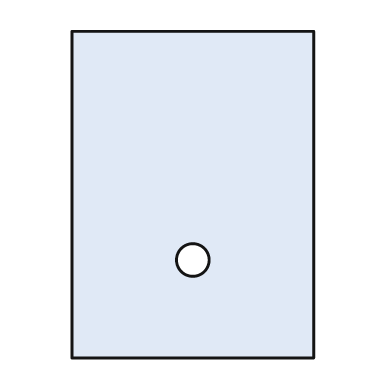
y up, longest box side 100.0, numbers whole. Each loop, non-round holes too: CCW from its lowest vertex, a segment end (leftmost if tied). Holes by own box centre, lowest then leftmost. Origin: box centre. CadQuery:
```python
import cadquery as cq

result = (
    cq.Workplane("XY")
    .moveTo(-37.0, -50.0)
    .lineTo(37.0, -50.0)
    .lineTo(37.0, 50.0)
    .lineTo(-37.0, 50.0)
    .close()
    .moveTo(0.0, -20.0)
    .circle(5.0)
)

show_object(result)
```